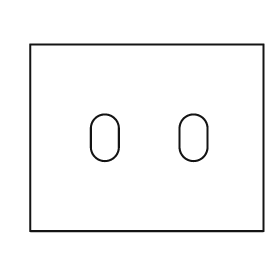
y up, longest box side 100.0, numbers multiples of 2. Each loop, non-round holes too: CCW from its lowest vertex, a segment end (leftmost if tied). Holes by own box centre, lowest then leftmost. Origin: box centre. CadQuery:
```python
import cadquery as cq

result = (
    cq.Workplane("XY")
    .moveTo(-50.0, -40.0)
    .lineTo(50.0, -40.0)
    .lineTo(50.0, 40.0)
    .lineTo(-50.0, 40.0)
    .close()
    .moveTo(-24.0, -4.0)
    .threePointArc((-18.0, -10.0), (-12.0, -4.0))
    .lineTo(-12.0, 4.0)
    .threePointArc((-18.0, 10.0), (-24.0, 4.0))
    .close()
    .moveTo(14.0, -4.0)
    .threePointArc((20.0, -10.0), (26.0, -4.0))
    .lineTo(26.0, 4.0)
    .threePointArc((20.0, 10.0), (14.0, 4.0))
    .close()
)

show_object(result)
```